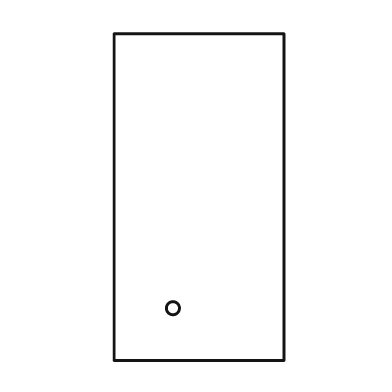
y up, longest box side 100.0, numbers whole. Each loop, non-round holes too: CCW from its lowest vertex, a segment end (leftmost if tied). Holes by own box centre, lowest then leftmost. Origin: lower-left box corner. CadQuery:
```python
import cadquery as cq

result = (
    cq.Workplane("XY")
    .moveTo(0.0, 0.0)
    .lineTo(52.0, 0.0)
    .lineTo(52.0, 100.0)
    .lineTo(0.0, 100.0)
    .close()
    .moveTo(18.0, 16.0)
    .circle(2.0)
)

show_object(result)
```